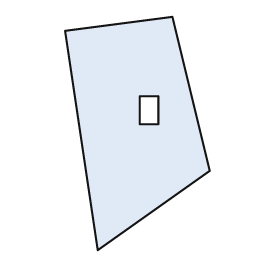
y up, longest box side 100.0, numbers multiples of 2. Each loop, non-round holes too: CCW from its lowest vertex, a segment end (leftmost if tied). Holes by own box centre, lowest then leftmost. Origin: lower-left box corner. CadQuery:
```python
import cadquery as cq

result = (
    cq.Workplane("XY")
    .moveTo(14.0, 0.0)
    .lineTo(62.0, 34.0)
    .lineTo(46.0, 100.0)
    .lineTo(0.0, 94.0)
    .close()
    .moveTo(32.0, 54.0)
    .lineTo(40.0, 54.0)
    .lineTo(40.0, 66.0)
    .lineTo(32.0, 66.0)
    .close()
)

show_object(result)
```